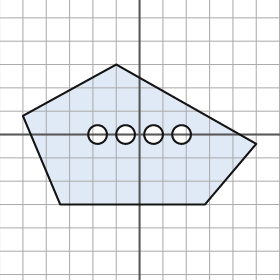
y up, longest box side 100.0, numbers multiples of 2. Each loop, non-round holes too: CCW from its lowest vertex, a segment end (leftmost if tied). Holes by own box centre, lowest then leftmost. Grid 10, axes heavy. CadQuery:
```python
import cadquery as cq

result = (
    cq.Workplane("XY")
    .moveTo(-34.0, -30.0)
    .lineTo(28.0, -30.0)
    .lineTo(50.0, -4.0)
    .lineTo(-10.0, 30.0)
    .lineTo(-50.0, 8.0)
    .close()
    .moveTo(-18.0, 0.0)
    .circle(4.0)
    .moveTo(-6.0, 0.0)
    .circle(4.0)
    .moveTo(6.0, 0.0)
    .circle(4.0)
    .moveTo(18.0, 0.0)
    .circle(4.0)
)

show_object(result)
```